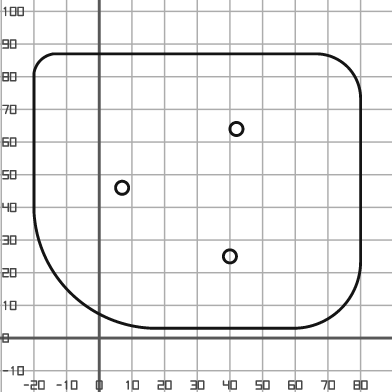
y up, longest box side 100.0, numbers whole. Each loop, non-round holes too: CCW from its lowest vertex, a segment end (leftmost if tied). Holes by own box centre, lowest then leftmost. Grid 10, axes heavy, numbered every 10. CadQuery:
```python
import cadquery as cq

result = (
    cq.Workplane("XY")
    .moveTo(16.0, 3.0)
    .lineTo(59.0, 3.0)
    .threePointArc((74.0, 9.0), (80.0, 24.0))
    .lineTo(80.0, 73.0)
    .threePointArc((76.0, 83.0), (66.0, 87.0))
    .lineTo(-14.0, 87.0)
    .threePointArc((-18.0, 85.0), (-20.0, 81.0))
    .lineTo(-20.0, 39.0)
    .threePointArc((-9.0, 14.0), (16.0, 3.0))
    .close()
    .moveTo(40.0, 25.0)
    .circle(2.0)
    .moveTo(7.0, 46.0)
    .circle(2.0)
    .moveTo(42.0, 64.0)
    .circle(2.0)
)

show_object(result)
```